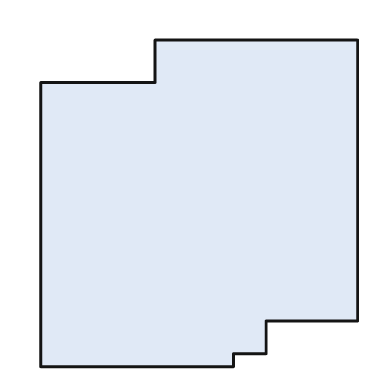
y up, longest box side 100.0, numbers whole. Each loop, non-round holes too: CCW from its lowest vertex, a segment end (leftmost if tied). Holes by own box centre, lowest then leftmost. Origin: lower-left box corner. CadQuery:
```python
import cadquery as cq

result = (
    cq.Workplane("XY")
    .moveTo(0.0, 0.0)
    .lineTo(59.0, 0.0)
    .lineTo(59.0, 4.0)
    .lineTo(69.0, 4.0)
    .lineTo(69.0, 14.0)
    .lineTo(97.0, 14.0)
    .lineTo(97.0, 100.0)
    .lineTo(35.0, 100.0)
    .lineTo(35.0, 87.0)
    .lineTo(0.0, 87.0)
    .close()
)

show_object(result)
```